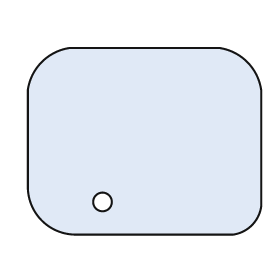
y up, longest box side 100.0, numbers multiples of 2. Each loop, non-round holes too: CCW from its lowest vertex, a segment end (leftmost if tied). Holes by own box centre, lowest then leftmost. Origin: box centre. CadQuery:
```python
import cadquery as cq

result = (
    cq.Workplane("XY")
    .moveTo(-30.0, -40.0)
    .lineTo(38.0, -40.0)
    .threePointArc((46.0, -36.0), (50.0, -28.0))
    .lineTo(50.0, 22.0)
    .threePointArc((44.0, 34.0), (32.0, 40.0))
    .lineTo(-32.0, 40.0)
    .threePointArc((-44.0, 34.0), (-50.0, 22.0))
    .lineTo(-50.0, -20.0)
    .threePointArc((-44.0, -34.0), (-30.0, -40.0))
    .close()
    .moveTo(-18.0, -26.0)
    .circle(4.0)
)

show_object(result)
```